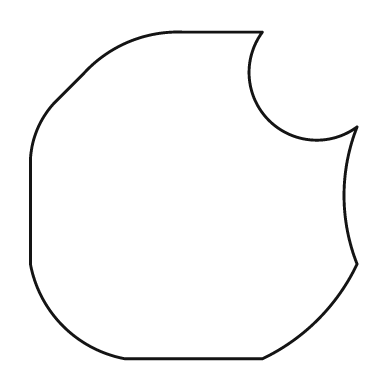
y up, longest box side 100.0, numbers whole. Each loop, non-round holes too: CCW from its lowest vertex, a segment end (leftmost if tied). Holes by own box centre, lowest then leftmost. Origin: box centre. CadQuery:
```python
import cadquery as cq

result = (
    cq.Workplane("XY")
    .moveTo(-21.0, -50.0)
    .lineTo(21.0, -50.0)
    .threePointArc((38.0, -38.0), (50.0, -21.0))
    .threePointArc((46.0, 0.0), (50.0, 21.0))
    .threePointArc((23.0, 23.0), (21.0, 50.0))
    .lineTo(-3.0, 50.0)
    .threePointArc((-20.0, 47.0), (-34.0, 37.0))
    .lineTo(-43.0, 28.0)
    .threePointArc((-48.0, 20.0), (-50.0, 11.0))
    .lineTo(-50.0, -21.0)
    .threePointArc((-40.0, -40.0), (-21.0, -50.0))
    .close()
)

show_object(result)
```